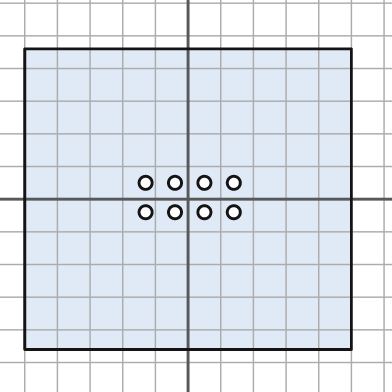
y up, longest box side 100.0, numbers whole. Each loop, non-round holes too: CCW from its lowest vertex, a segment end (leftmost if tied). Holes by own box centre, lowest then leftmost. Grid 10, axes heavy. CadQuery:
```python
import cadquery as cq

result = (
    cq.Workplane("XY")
    .moveTo(-50.0, -46.0)
    .lineTo(50.0, -46.0)
    .lineTo(50.0, 46.0)
    .lineTo(-50.0, 46.0)
    .close()
    .moveTo(-13.0, -4.0)
    .circle(2.0)
    .moveTo(-4.0, -4.0)
    .circle(2.0)
    .moveTo(5.0, -4.0)
    .circle(2.0)
    .moveTo(14.0, -4.0)
    .circle(2.0)
    .moveTo(-13.0, 5.0)
    .circle(2.0)
    .moveTo(-4.0, 5.0)
    .circle(2.0)
    .moveTo(5.0, 5.0)
    .circle(2.0)
    .moveTo(14.0, 5.0)
    .circle(2.0)
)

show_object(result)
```